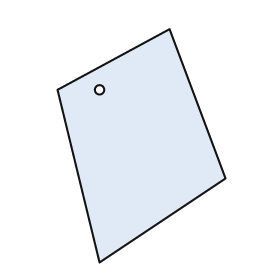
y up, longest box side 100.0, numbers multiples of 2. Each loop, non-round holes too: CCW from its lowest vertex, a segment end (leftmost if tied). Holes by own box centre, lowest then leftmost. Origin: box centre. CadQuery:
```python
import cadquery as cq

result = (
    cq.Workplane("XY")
    .moveTo(-18.0, -50.0)
    .lineTo(36.0, -14.0)
    .lineTo(12.0, 50.0)
    .lineTo(-36.0, 24.0)
    .close()
    .moveTo(-18.0, 24.0)
    .circle(2.0)
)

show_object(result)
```